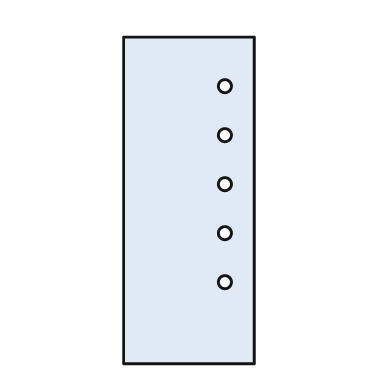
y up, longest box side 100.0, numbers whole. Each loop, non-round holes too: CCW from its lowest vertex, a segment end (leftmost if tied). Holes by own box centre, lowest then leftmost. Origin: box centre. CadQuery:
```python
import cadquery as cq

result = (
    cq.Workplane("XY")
    .moveTo(-20.0, -50.0)
    .lineTo(20.0, -50.0)
    .lineTo(20.0, 50.0)
    .lineTo(-20.0, 50.0)
    .close()
    .moveTo(11.0, -25.0)
    .circle(2.0)
    .moveTo(11.0, -10.0)
    .circle(2.0)
    .moveTo(11.0, 5.0)
    .circle(2.0)
    .moveTo(11.0, 20.0)
    .circle(2.0)
    .moveTo(11.0, 35.0)
    .circle(2.0)
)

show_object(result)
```